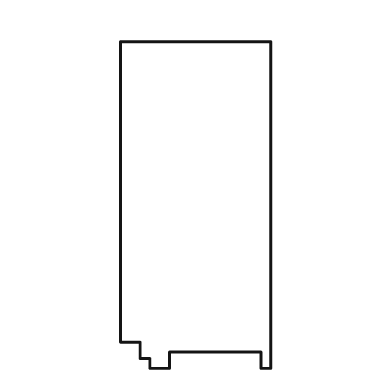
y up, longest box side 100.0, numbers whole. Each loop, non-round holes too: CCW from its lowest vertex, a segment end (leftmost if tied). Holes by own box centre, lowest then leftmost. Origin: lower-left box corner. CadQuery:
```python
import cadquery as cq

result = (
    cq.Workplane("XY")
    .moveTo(9.0, 0.0)
    .lineTo(15.0, 0.0)
    .lineTo(15.0, 5.0)
    .lineTo(43.0, 5.0)
    .lineTo(43.0, 0.0)
    .lineTo(46.0, 0.0)
    .lineTo(46.0, 100.0)
    .lineTo(0.0, 100.0)
    .lineTo(0.0, 8.0)
    .lineTo(6.0, 8.0)
    .lineTo(6.0, 3.0)
    .lineTo(9.0, 3.0)
    .close()
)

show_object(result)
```